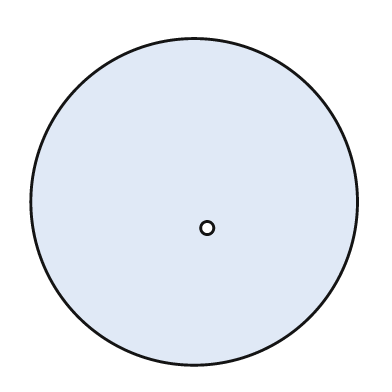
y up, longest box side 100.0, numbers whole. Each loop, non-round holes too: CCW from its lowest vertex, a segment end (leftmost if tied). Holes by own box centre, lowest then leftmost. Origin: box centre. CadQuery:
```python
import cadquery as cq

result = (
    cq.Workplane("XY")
    .moveTo(0.0, 0.0)
    .circle(50.0)
    .moveTo(4.0, -8.0)
    .circle(2.0)
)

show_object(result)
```